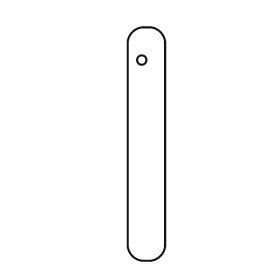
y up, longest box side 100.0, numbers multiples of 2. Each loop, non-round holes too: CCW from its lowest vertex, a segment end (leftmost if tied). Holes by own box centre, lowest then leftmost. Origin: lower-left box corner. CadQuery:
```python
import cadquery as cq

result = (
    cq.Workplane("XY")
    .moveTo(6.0, 0.0)
    .lineTo(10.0, 0.0)
    .threePointArc((14.0, 2.0), (16.0, 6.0))
    .lineTo(16.0, 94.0)
    .threePointArc((14.0, 98.0), (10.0, 100.0))
    .lineTo(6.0, 100.0)
    .threePointArc((2.0, 98.0), (0.0, 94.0))
    .lineTo(0.0, 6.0)
    .threePointArc((2.0, 2.0), (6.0, 0.0))
    .close()
    .moveTo(6.0, 86.0)
    .circle(2.0)
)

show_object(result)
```